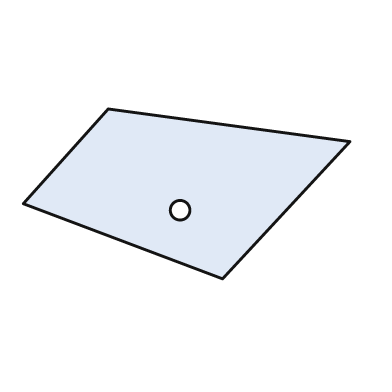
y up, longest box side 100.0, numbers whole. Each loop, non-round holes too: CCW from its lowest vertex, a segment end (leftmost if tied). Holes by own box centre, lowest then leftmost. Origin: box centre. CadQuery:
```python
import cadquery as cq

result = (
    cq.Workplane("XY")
    .moveTo(11.0, -26.0)
    .lineTo(50.0, 16.0)
    .lineTo(-24.0, 26.0)
    .lineTo(-50.0, -3.0)
    .close()
    .moveTo(-2.0, -5.0)
    .circle(3.0)
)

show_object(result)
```